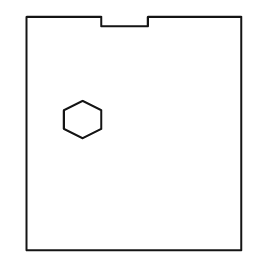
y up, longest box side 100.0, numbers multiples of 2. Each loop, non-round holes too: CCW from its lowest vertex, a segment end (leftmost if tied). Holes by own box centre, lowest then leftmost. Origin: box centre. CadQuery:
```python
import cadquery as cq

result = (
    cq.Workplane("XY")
    .moveTo(-46.0, -50.0)
    .lineTo(46.0, -50.0)
    .lineTo(46.0, 50.0)
    .lineTo(6.0, 50.0)
    .lineTo(6.0, 46.0)
    .lineTo(-14.0, 46.0)
    .lineTo(-14.0, 50.0)
    .lineTo(-46.0, 50.0)
    .close()
    .moveTo(-22.0, -2.0)
    .lineTo(-14.0, 2.0)
    .lineTo(-14.0, 10.0)
    .lineTo(-22.0, 14.0)
    .lineTo(-30.0, 10.0)
    .lineTo(-30.0, 2.0)
    .close()
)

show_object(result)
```